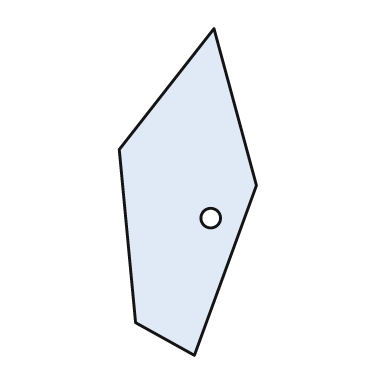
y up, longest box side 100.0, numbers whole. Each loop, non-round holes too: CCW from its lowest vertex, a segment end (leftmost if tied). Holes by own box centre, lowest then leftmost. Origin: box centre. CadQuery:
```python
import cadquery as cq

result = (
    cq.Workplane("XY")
    .moveTo(2.0, -50.0)
    .lineTo(21.0, 2.0)
    .lineTo(8.0, 50.0)
    .lineTo(-21.0, 13.0)
    .lineTo(-16.0, -40.0)
    .close()
    .moveTo(7.0, -8.0)
    .circle(3.0)
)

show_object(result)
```